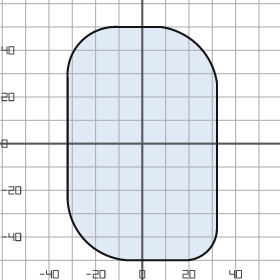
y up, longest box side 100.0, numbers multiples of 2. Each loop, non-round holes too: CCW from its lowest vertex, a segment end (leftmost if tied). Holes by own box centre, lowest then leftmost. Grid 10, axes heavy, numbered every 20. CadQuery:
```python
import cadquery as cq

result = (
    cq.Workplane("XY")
    .moveTo(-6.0, -50.0)
    .lineTo(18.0, -50.0)
    .threePointArc((28.0, -46.0), (32.0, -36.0))
    .lineTo(32.0, 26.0)
    .threePointArc((24.0, 42.0), (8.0, 50.0))
    .lineTo(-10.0, 50.0)
    .threePointArc((-26.0, 44.0), (-32.0, 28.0))
    .lineTo(-32.0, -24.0)
    .threePointArc((-24.0, -42.0), (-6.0, -50.0))
    .close()
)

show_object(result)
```